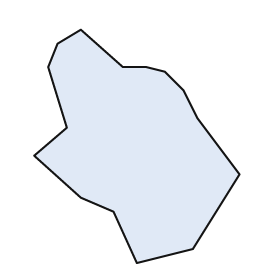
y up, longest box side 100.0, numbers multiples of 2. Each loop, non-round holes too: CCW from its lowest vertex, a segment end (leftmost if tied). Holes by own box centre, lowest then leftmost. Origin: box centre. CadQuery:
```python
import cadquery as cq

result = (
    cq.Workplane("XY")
    .moveTo(0.0, -50.0)
    .lineTo(24.0, -44.0)
    .lineTo(44.0, -12.0)
    .lineTo(26.0, 12.0)
    .lineTo(20.0, 24.0)
    .lineTo(12.0, 32.0)
    .lineTo(4.0, 34.0)
    .lineTo(-6.0, 34.0)
    .lineTo(-24.0, 50.0)
    .lineTo(-34.0, 44.0)
    .lineTo(-38.0, 34.0)
    .lineTo(-30.0, 8.0)
    .lineTo(-44.0, -4.0)
    .lineTo(-24.0, -22.0)
    .lineTo(-10.0, -28.0)
    .close()
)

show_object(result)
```